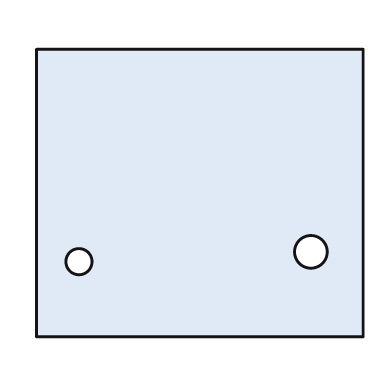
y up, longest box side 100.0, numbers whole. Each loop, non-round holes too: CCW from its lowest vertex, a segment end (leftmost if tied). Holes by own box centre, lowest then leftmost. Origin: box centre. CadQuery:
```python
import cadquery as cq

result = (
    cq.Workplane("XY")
    .moveTo(-50.0, -44.0)
    .lineTo(50.0, -44.0)
    .lineTo(50.0, 44.0)
    .lineTo(-50.0, 44.0)
    .close()
    .moveTo(-37.0, -21.0)
    .circle(4.0)
    .moveTo(34.0, -18.0)
    .circle(5.0)
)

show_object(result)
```